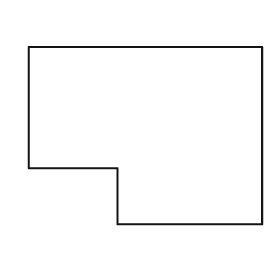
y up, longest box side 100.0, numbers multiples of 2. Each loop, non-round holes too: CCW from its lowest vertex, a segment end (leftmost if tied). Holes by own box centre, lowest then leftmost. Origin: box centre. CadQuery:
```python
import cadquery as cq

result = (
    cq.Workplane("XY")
    .moveTo(-12.0, -38.0)
    .lineTo(50.0, -38.0)
    .lineTo(50.0, 38.0)
    .lineTo(-50.0, 38.0)
    .lineTo(-50.0, -14.0)
    .lineTo(-12.0, -14.0)
    .close()
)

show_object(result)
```